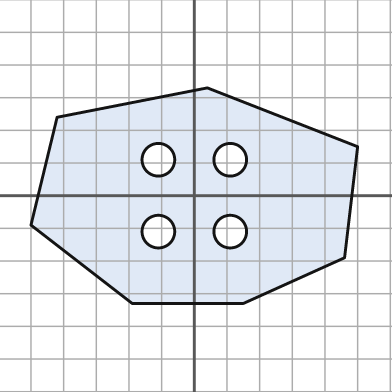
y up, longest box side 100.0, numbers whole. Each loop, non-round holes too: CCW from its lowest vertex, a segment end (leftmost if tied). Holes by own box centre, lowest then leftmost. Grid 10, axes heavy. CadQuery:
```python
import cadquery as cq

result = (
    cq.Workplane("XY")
    .moveTo(-19.0, -33.0)
    .lineTo(15.0, -33.0)
    .lineTo(46.0, -19.0)
    .lineTo(50.0, 15.0)
    .lineTo(4.0, 33.0)
    .lineTo(-42.0, 24.0)
    .lineTo(-50.0, -9.0)
    .close()
    .moveTo(-11.0, -11.0)
    .circle(5.0)
    .moveTo(11.0, -11.0)
    .circle(5.0)
    .moveTo(-11.0, 11.0)
    .circle(5.0)
    .moveTo(11.0, 11.0)
    .circle(5.0)
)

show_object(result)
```